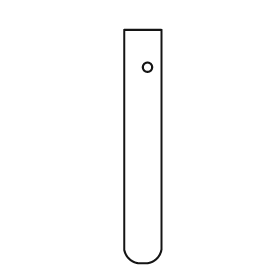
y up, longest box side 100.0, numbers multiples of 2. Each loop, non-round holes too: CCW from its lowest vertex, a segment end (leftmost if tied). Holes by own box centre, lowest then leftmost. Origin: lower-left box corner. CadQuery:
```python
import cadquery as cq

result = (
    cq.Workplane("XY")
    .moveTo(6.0, 0.0)
    .lineTo(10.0, 0.0)
    .threePointArc((14.0, 2.0), (16.0, 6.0))
    .lineTo(16.0, 100.0)
    .lineTo(0.0, 100.0)
    .lineTo(0.0, 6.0)
    .threePointArc((2.0, 2.0), (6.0, 0.0))
    .close()
    .moveTo(10.0, 84.0)
    .circle(2.0)
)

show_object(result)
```